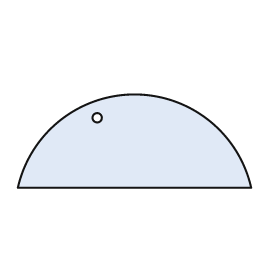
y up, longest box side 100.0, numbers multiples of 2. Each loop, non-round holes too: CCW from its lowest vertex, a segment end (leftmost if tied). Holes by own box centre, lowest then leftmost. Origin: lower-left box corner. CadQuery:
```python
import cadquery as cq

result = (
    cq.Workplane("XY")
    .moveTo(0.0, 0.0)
    .lineTo(100.0, 0.0)
    .threePointArc((50.0, 40.0), (0.0, 0.0))
    .close()
    .moveTo(34.0, 30.0)
    .circle(2.0)
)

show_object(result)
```